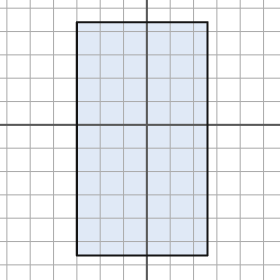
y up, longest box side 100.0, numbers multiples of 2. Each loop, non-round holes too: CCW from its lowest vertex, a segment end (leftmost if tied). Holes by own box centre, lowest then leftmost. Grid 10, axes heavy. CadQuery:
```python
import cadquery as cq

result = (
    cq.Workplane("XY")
    .moveTo(-30.0, -56.0)
    .lineTo(26.0, -56.0)
    .lineTo(26.0, 44.0)
    .lineTo(-30.0, 44.0)
    .close()
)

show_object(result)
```